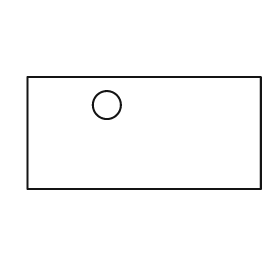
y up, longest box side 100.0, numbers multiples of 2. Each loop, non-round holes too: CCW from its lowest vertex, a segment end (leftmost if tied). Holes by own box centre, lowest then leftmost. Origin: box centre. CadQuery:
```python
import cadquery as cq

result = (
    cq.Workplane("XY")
    .moveTo(-50.0, -24.0)
    .lineTo(50.0, -24.0)
    .lineTo(50.0, 24.0)
    .lineTo(-50.0, 24.0)
    .close()
    .moveTo(-16.0, 12.0)
    .circle(6.0)
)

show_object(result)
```